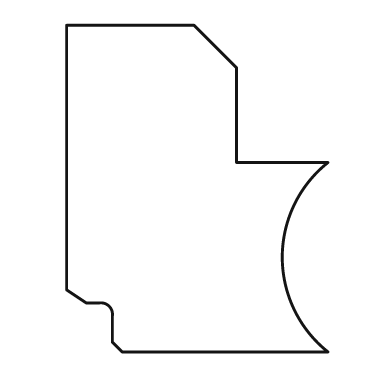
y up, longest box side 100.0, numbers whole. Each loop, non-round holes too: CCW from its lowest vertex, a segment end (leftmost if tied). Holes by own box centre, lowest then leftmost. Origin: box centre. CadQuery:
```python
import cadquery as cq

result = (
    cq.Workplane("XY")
    .moveTo(-23.0, -50.0)
    .lineTo(40.0, -50.0)
    .threePointArc((26.0, -21.0), (40.0, 8.0))
    .lineTo(12.0, 8.0)
    .lineTo(12.0, 37.0)
    .lineTo(-1.0, 50.0)
    .lineTo(-40.0, 50.0)
    .lineTo(-40.0, -31.0)
    .lineTo(-34.0, -35.0)
    .lineTo(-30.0, -35.0)
    .threePointArc((-27.0, -36.0), (-26.0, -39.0))
    .lineTo(-26.0, -47.0)
    .close()
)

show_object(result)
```